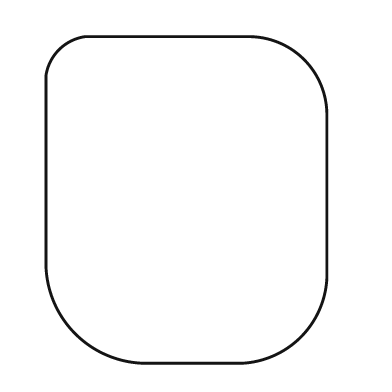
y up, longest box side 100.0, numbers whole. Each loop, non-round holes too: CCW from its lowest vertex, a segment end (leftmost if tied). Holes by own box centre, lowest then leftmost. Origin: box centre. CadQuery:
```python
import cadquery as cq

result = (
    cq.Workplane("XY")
    .moveTo(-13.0, -50.0)
    .lineTo(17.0, -50.0)
    .threePointArc((35.0, -42.0), (43.0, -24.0))
    .lineTo(43.0, 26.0)
    .threePointArc((36.0, 43.0), (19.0, 50.0))
    .lineTo(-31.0, 50.0)
    .threePointArc((-39.0, 46.0), (-43.0, 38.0))
    .lineTo(-43.0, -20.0)
    .threePointArc((-34.0, -41.0), (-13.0, -50.0))
    .close()
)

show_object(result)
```